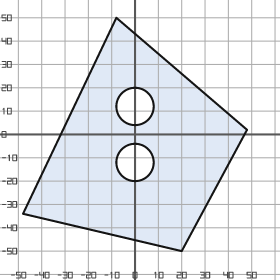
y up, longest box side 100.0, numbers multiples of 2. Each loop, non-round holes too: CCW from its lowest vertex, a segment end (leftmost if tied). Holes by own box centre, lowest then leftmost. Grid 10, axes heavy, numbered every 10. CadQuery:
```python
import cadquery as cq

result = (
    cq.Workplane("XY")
    .moveTo(20.0, -50.0)
    .lineTo(48.0, 2.0)
    .lineTo(-8.0, 50.0)
    .lineTo(-48.0, -34.0)
    .close()
    .moveTo(0.0, -12.0)
    .circle(8.0)
    .moveTo(0.0, 12.0)
    .circle(8.0)
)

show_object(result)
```